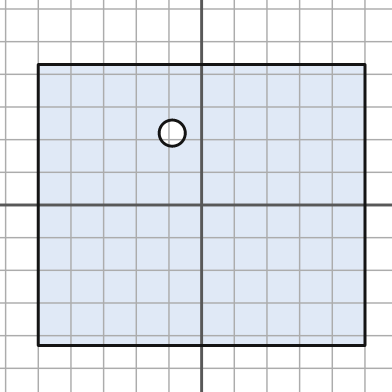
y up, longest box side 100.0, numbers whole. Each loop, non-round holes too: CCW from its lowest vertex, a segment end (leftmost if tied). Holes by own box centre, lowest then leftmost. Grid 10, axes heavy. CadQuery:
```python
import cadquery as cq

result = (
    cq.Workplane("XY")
    .moveTo(-50.0, -43.0)
    .lineTo(50.0, -43.0)
    .lineTo(50.0, 43.0)
    .lineTo(-50.0, 43.0)
    .close()
    .moveTo(-9.0, 22.0)
    .circle(4.0)
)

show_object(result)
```